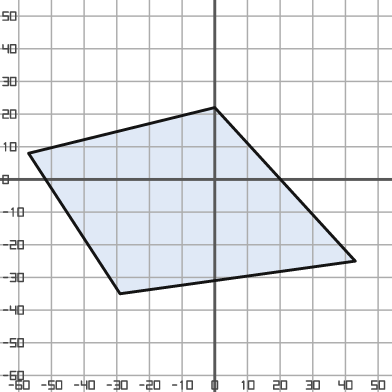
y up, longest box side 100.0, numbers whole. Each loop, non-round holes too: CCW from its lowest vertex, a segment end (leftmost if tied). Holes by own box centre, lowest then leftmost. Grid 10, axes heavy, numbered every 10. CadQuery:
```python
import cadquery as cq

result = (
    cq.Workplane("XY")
    .moveTo(-29.0, -35.0)
    .lineTo(43.0, -25.0)
    .lineTo(0.0, 22.0)
    .lineTo(-57.0, 8.0)
    .close()
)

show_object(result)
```